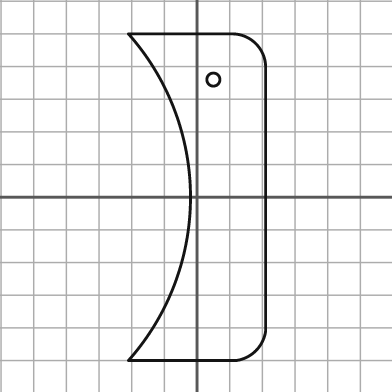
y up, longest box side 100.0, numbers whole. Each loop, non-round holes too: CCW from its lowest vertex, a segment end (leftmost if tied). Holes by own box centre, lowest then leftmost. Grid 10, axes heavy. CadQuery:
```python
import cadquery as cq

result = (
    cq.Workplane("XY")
    .moveTo(-21.0, -50.0)
    .lineTo(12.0, -50.0)
    .threePointArc((18.0, -47.0), (21.0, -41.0))
    .lineTo(21.0, 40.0)
    .threePointArc((18.0, 47.0), (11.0, 50.0))
    .lineTo(-21.0, 50.0)
    .threePointArc((-2.0, 0.0), (-21.0, -50.0))
    .close()
    .moveTo(5.0, 36.0)
    .circle(2.0)
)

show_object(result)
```